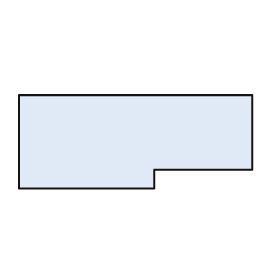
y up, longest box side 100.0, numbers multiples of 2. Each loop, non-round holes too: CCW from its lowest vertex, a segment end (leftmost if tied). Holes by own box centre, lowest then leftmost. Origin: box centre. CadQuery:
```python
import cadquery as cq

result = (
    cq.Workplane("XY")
    .moveTo(-50.0, -20.0)
    .lineTo(8.0, -20.0)
    .lineTo(8.0, -12.0)
    .lineTo(50.0, -12.0)
    .lineTo(50.0, 20.0)
    .lineTo(-50.0, 20.0)
    .close()
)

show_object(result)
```